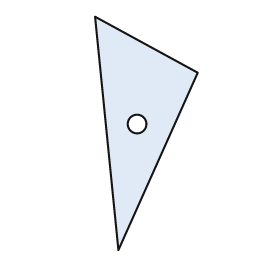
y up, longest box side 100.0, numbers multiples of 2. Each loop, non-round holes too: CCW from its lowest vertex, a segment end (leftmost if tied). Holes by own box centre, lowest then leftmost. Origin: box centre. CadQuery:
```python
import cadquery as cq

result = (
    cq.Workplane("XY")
    .moveTo(-12.0, -50.0)
    .lineTo(22.0, 26.0)
    .lineTo(-22.0, 50.0)
    .close()
    .moveTo(-4.0, 4.0)
    .circle(4.0)
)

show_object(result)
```